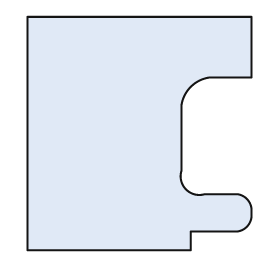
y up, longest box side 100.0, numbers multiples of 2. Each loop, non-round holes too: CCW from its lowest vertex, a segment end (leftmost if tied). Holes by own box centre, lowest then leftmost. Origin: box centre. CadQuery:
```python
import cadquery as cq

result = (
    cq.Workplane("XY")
    .moveTo(-48.0, -50.0)
    .lineTo(22.0, -50.0)
    .lineTo(22.0, -42.0)
    .lineTo(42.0, -42.0)
    .threePointArc((46.0, -40.0), (48.0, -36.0))
    .lineTo(48.0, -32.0)
    .threePointArc((46.0, -28.0), (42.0, -26.0))
    .lineTo(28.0, -26.0)
    .threePointArc((20.0, -24.0), (18.0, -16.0))
    .lineTo(18.0, 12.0)
    .threePointArc((22.0, 20.0), (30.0, 24.0))
    .lineTo(48.0, 24.0)
    .lineTo(48.0, 50.0)
    .lineTo(-48.0, 50.0)
    .close()
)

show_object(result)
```